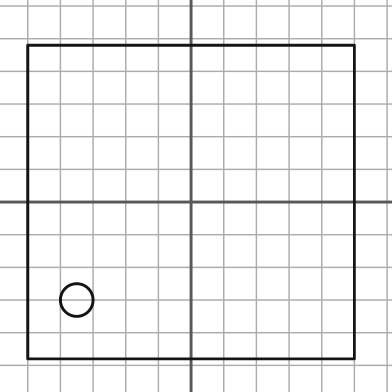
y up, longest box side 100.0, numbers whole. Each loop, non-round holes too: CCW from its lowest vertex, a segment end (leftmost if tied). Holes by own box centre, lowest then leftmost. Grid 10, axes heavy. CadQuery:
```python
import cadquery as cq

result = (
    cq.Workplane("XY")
    .moveTo(-50.0, -48.0)
    .lineTo(50.0, -48.0)
    .lineTo(50.0, 48.0)
    .lineTo(-50.0, 48.0)
    .close()
    .moveTo(-35.0, -30.0)
    .circle(5.0)
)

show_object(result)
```